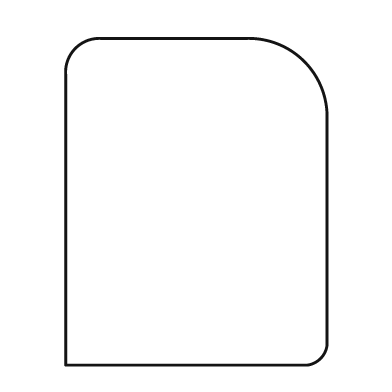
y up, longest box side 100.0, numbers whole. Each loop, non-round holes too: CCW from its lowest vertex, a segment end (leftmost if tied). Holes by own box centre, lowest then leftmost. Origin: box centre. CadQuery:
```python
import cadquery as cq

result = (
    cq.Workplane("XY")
    .moveTo(-40.0, -50.0)
    .lineTo(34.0, -50.0)
    .threePointArc((38.0, -48.0), (40.0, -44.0))
    .lineTo(40.0, 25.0)
    .threePointArc((33.0, 43.0), (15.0, 50.0))
    .lineTo(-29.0, 50.0)
    .threePointArc((-37.0, 47.0), (-40.0, 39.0))
    .close()
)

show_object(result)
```